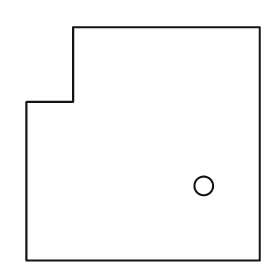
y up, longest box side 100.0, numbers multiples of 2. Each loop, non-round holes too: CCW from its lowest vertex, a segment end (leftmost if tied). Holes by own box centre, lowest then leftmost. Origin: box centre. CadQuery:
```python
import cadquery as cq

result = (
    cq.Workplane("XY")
    .moveTo(-50.0, -50.0)
    .lineTo(50.0, -50.0)
    .lineTo(50.0, 50.0)
    .lineTo(-30.0, 50.0)
    .lineTo(-30.0, 18.0)
    .lineTo(-50.0, 18.0)
    .close()
    .moveTo(26.0, -18.0)
    .circle(4.0)
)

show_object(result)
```